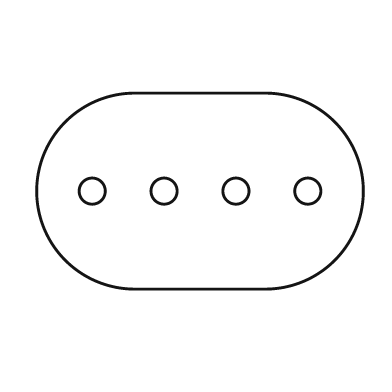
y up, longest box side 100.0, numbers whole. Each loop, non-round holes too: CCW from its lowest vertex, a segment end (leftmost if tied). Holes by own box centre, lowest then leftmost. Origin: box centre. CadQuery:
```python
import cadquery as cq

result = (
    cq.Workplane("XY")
    .moveTo(-20.0, -30.0)
    .lineTo(20.0, -30.0)
    .threePointArc((50.0, 0.0), (20.0, 30.0))
    .lineTo(-20.0, 30.0)
    .threePointArc((-50.0, 0.0), (-20.0, -30.0))
    .close()
    .moveTo(-33.0, 0.0)
    .circle(4.0)
    .moveTo(-11.0, 0.0)
    .circle(4.0)
    .moveTo(11.0, 0.0)
    .circle(4.0)
    .moveTo(33.0, 0.0)
    .circle(4.0)
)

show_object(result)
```